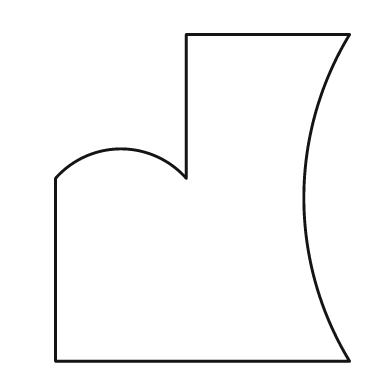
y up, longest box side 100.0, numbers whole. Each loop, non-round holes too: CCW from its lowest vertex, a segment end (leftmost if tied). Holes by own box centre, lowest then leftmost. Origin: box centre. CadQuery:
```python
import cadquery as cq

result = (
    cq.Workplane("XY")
    .moveTo(-45.0, -50.0)
    .lineTo(45.0, -50.0)
    .threePointArc((31.0, 0.0), (45.0, 50.0))
    .lineTo(-5.0, 50.0)
    .lineTo(-5.0, 6.0)
    .threePointArc((-25.0, 15.0), (-45.0, 6.0))
    .close()
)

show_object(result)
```